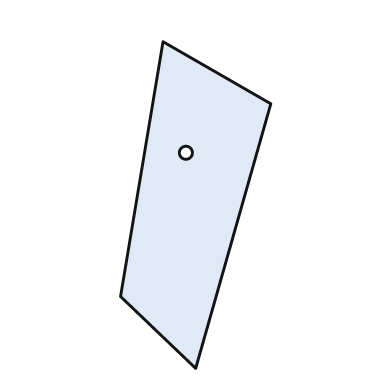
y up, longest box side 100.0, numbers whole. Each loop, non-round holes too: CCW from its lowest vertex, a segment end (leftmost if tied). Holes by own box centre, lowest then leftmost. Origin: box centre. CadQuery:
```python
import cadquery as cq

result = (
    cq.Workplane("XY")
    .moveTo(0.0, -50.0)
    .lineTo(23.0, 31.0)
    .lineTo(-10.0, 50.0)
    .lineTo(-23.0, -28.0)
    .close()
    .moveTo(-3.0, 16.0)
    .circle(2.0)
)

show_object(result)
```